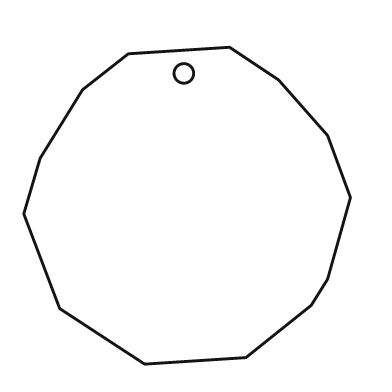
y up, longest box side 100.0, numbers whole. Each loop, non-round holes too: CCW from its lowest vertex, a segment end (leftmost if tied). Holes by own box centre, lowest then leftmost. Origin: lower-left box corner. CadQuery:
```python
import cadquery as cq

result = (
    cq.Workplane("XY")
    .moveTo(37.0, 0.0)
    .lineTo(68.0, 2.0)
    .lineTo(88.0, 18.0)
    .lineTo(93.0, 26.0)
    .lineTo(100.0, 51.0)
    .lineTo(93.0, 70.0)
    .lineTo(78.0, 87.0)
    .lineTo(63.0, 97.0)
    .lineTo(32.0, 95.0)
    .lineTo(18.0, 84.0)
    .lineTo(5.0, 63.0)
    .lineTo(0.0, 46.0)
    .lineTo(11.0, 17.0)
    .close()
    .moveTo(49.0, 89.0)
    .circle(3.0)
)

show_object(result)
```